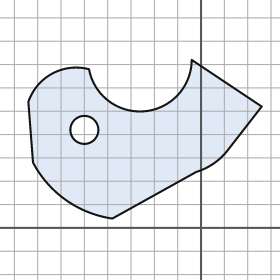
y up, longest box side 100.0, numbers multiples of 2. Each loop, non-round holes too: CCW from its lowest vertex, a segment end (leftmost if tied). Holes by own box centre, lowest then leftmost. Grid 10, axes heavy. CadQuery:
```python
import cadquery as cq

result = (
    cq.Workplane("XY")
    .moveTo(-38.0, 4.0)
    .lineTo(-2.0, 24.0)
    .threePointArc((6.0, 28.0), (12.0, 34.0))
    .lineTo(26.0, 52.0)
    .lineTo(-4.0, 72.0)
    .threePointArc((-24.0, 50.0), (-48.0, 68.0))
    .threePointArc((-64.0, 66.0), (-74.0, 54.0))
    .lineTo(-72.0, 28.0)
    .threePointArc((-58.0, 12.0), (-38.0, 4.0))
    .close()
    .moveTo(-50.0, 42.0)
    .circle(6.0)
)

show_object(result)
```